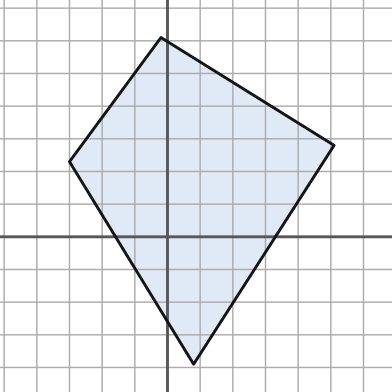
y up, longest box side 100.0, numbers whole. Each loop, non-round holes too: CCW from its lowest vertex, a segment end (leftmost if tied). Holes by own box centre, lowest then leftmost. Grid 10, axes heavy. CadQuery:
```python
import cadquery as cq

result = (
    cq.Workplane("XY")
    .moveTo(8.0, -39.0)
    .lineTo(51.0, 28.0)
    .lineTo(-2.0, 61.0)
    .lineTo(-30.0, 23.0)
    .close()
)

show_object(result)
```